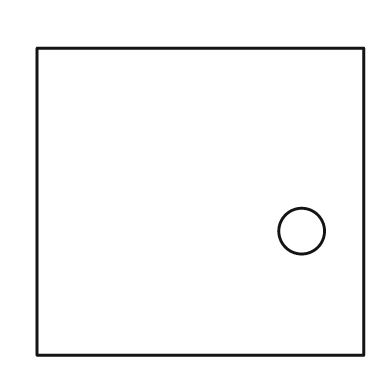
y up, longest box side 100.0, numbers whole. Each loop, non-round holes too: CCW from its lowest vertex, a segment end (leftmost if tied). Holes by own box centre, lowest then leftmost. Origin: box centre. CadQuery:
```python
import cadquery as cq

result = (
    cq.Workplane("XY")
    .moveTo(-50.0, -47.0)
    .lineTo(50.0, -47.0)
    .lineTo(50.0, 47.0)
    .lineTo(-50.0, 47.0)
    .close()
    .moveTo(31.0, -9.0)
    .circle(7.0)
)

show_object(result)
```